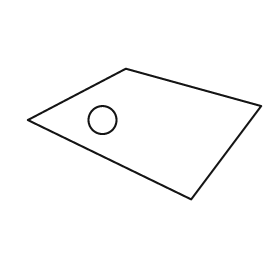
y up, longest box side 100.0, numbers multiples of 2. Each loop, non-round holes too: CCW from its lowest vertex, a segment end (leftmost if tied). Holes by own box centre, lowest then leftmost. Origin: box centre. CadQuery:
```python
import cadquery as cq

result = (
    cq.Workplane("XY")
    .moveTo(20.0, -28.0)
    .lineTo(50.0, 12.0)
    .lineTo(-8.0, 28.0)
    .lineTo(-50.0, 6.0)
    .close()
    .moveTo(-18.0, 6.0)
    .circle(6.0)
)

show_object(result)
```